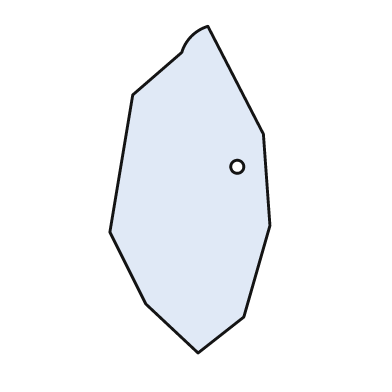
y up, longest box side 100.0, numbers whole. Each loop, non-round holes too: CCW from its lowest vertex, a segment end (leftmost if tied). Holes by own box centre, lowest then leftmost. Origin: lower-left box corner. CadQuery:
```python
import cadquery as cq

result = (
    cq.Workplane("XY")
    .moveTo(27.0, 0.0)
    .lineTo(41.0, 11.0)
    .lineTo(49.0, 39.0)
    .lineTo(47.0, 67.0)
    .lineTo(30.0, 100.0)
    .threePointArc((25.0, 97.0), (22.0, 92.0))
    .lineTo(7.0, 79.0)
    .lineTo(0.0, 37.0)
    .lineTo(11.0, 15.0)
    .close()
    .moveTo(39.0, 57.0)
    .circle(2.0)
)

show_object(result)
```